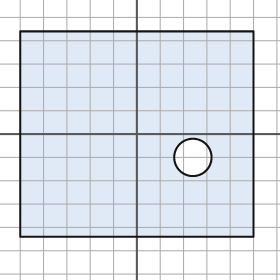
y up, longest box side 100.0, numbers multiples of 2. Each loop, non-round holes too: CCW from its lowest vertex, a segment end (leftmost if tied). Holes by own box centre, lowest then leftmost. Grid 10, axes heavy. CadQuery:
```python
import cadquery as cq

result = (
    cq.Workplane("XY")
    .moveTo(-50.0, -44.0)
    .lineTo(50.0, -44.0)
    .lineTo(50.0, 44.0)
    .lineTo(-50.0, 44.0)
    .close()
    .moveTo(24.0, -10.0)
    .circle(8.0)
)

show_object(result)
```